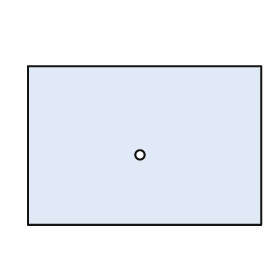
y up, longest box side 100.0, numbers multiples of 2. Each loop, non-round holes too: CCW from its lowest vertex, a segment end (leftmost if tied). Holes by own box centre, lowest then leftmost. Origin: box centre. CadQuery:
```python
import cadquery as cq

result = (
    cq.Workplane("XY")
    .moveTo(-50.0, -34.0)
    .lineTo(50.0, -34.0)
    .lineTo(50.0, 34.0)
    .lineTo(-50.0, 34.0)
    .close()
    .moveTo(-2.0, -4.0)
    .circle(2.0)
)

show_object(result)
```